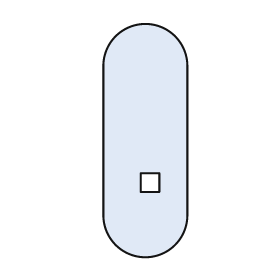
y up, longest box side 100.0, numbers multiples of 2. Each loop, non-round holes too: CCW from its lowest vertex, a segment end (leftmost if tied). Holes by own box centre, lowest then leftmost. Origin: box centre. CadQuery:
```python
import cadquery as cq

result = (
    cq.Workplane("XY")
    .moveTo(-18.0, -32.0)
    .threePointArc((0.0, -50.0), (18.0, -32.0))
    .lineTo(18.0, 32.0)
    .threePointArc((0.0, 50.0), (-18.0, 32.0))
    .close()
    .moveTo(-2.0, -22.0)
    .lineTo(6.0, -22.0)
    .lineTo(6.0, -14.0)
    .lineTo(-2.0, -14.0)
    .close()
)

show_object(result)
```